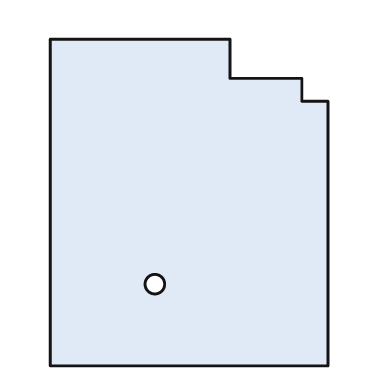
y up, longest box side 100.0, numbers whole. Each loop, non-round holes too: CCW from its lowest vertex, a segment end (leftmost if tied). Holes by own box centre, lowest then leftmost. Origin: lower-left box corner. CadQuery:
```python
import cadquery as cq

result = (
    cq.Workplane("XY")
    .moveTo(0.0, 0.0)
    .lineTo(85.0, 0.0)
    .lineTo(85.0, 81.0)
    .lineTo(77.0, 81.0)
    .lineTo(77.0, 88.0)
    .lineTo(55.0, 88.0)
    .lineTo(55.0, 100.0)
    .lineTo(0.0, 100.0)
    .close()
    .moveTo(32.0, 25.0)
    .circle(3.0)
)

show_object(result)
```